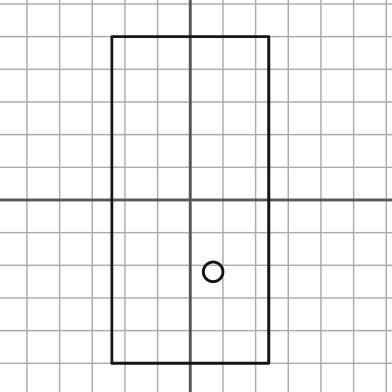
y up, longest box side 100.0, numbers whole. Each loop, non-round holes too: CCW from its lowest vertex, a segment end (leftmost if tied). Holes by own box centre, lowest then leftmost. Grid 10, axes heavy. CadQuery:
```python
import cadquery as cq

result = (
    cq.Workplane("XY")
    .moveTo(-24.0, -50.0)
    .lineTo(24.0, -50.0)
    .lineTo(24.0, 50.0)
    .lineTo(-24.0, 50.0)
    .close()
    .moveTo(7.0, -22.0)
    .circle(3.0)
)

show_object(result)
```